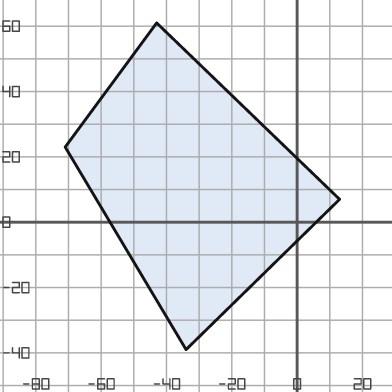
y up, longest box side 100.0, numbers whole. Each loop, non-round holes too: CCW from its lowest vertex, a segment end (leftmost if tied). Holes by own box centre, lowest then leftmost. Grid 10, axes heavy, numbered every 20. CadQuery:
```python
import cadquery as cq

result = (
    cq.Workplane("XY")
    .moveTo(-34.0, -39.0)
    .lineTo(13.0, 7.0)
    .lineTo(-43.0, 61.0)
    .lineTo(-71.0, 23.0)
    .close()
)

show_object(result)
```